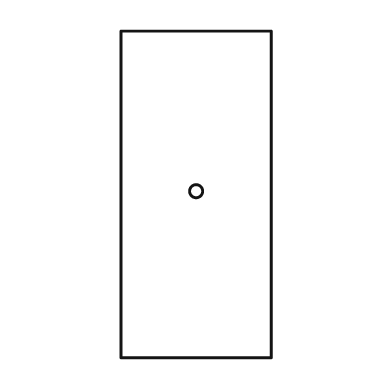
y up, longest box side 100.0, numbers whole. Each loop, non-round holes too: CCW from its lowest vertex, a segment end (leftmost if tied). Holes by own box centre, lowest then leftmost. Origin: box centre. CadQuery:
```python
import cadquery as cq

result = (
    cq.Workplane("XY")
    .moveTo(-23.0, -50.0)
    .lineTo(23.0, -50.0)
    .lineTo(23.0, 50.0)
    .lineTo(-23.0, 50.0)
    .close()
    .moveTo(0.0, 1.0)
    .circle(2.0)
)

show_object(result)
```